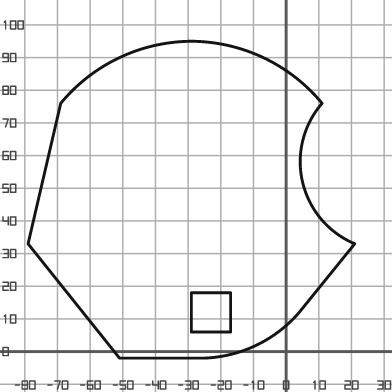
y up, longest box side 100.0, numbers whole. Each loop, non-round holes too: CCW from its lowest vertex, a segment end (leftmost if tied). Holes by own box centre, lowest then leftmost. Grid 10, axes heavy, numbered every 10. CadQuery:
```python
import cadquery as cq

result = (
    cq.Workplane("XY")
    .moveTo(-51.0, -2.0)
    .lineTo(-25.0, -2.0)
    .threePointArc((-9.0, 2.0), (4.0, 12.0))
    .lineTo(21.0, 33.0)
    .threePointArc((5.0, 52.0), (11.0, 76.0))
    .threePointArc((-7.0, 90.0), (-29.0, 95.0))
    .threePointArc((-51.0, 90.0), (-69.0, 76.0))
    .lineTo(-79.0, 33.0)
    .close()
    .moveTo(-29.0, 6.0)
    .lineTo(-17.0, 6.0)
    .lineTo(-17.0, 18.0)
    .lineTo(-29.0, 18.0)
    .close()
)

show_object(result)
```